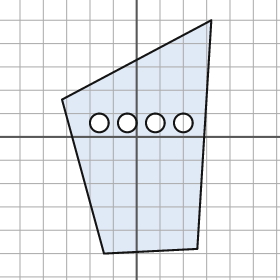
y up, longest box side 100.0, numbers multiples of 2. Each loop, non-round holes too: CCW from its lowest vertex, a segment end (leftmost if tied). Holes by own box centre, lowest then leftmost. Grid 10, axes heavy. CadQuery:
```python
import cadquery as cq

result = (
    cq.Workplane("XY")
    .moveTo(-14.0, -50.0)
    .lineTo(26.0, -48.0)
    .lineTo(32.0, 50.0)
    .lineTo(-32.0, 16.0)
    .close()
    .moveTo(-16.0, 6.0)
    .circle(4.0)
    .moveTo(-4.0, 6.0)
    .circle(4.0)
    .moveTo(8.0, 6.0)
    .circle(4.0)
    .moveTo(20.0, 6.0)
    .circle(4.0)
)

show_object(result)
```